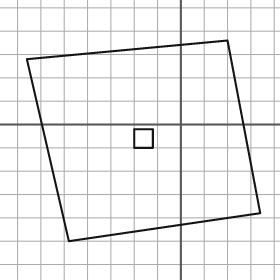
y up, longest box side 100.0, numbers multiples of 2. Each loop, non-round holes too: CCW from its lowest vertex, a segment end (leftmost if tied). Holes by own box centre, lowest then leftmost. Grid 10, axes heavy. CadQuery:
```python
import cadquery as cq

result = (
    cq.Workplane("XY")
    .moveTo(-48.0, -50.0)
    .lineTo(34.0, -38.0)
    .lineTo(20.0, 36.0)
    .lineTo(-66.0, 28.0)
    .close()
    .moveTo(-20.0, -10.0)
    .lineTo(-12.0, -10.0)
    .lineTo(-12.0, -2.0)
    .lineTo(-20.0, -2.0)
    .close()
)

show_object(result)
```